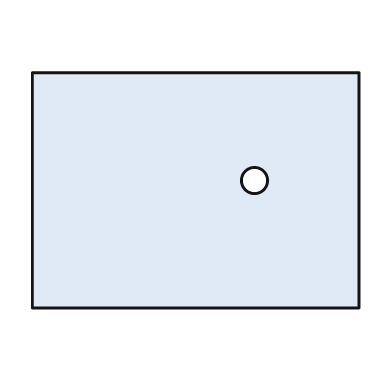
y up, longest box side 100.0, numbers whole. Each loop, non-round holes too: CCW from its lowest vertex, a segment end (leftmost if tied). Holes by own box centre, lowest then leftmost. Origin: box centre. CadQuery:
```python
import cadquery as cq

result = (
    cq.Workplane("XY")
    .moveTo(-50.0, -36.0)
    .lineTo(50.0, -36.0)
    .lineTo(50.0, 36.0)
    .lineTo(-50.0, 36.0)
    .close()
    .moveTo(18.0, 3.0)
    .circle(4.0)
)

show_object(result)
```